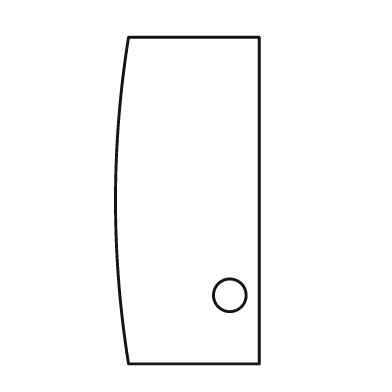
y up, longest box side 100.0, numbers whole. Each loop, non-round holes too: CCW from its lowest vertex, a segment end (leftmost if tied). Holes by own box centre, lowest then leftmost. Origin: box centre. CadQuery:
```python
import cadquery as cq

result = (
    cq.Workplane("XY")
    .moveTo(-18.0, -50.0)
    .lineTo(22.0, -50.0)
    .lineTo(22.0, 50.0)
    .lineTo(-18.0, 50.0)
    .threePointArc((-22.0, 0.0), (-18.0, -50.0))
    .close()
    .moveTo(13.0, -29.0)
    .circle(5.0)
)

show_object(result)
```